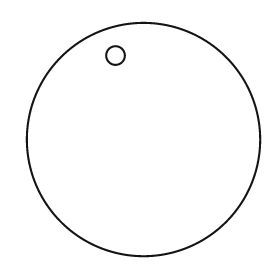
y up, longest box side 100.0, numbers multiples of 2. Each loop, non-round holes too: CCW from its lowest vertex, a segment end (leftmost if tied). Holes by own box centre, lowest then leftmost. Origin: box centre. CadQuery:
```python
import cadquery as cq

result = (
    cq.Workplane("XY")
    .moveTo(0.0, 0.0)
    .circle(50.0)
    .moveTo(-12.0, 36.0)
    .circle(4.0)
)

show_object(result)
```